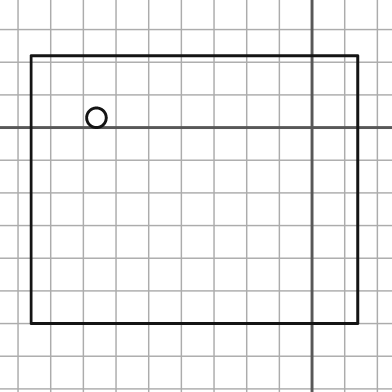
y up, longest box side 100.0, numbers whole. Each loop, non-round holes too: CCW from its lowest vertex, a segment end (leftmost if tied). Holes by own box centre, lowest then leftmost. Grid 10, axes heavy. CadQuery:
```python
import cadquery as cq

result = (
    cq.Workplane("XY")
    .moveTo(-86.0, -60.0)
    .lineTo(14.0, -60.0)
    .lineTo(14.0, 22.0)
    .lineTo(-86.0, 22.0)
    .close()
    .moveTo(-66.0, 3.0)
    .circle(3.0)
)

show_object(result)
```